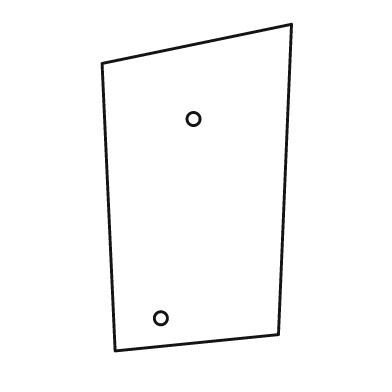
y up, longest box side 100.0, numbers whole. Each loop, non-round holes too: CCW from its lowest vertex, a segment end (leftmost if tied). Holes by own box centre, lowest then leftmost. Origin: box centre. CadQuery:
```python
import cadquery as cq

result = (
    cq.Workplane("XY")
    .moveTo(-25.0, -50.0)
    .lineTo(25.0, -45.0)
    .lineTo(29.0, 50.0)
    .lineTo(-29.0, 38.0)
    .close()
    .moveTo(-11.0, -40.0)
    .circle(2.0)
    .moveTo(-1.0, 21.0)
    .circle(2.0)
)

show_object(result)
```